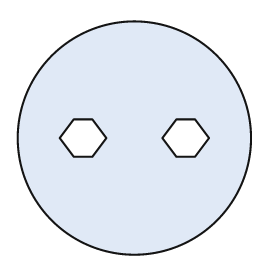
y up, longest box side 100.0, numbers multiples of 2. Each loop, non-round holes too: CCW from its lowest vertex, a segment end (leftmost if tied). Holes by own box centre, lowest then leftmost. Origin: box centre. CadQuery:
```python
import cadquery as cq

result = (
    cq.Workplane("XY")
    .moveTo(0.0, 0.0)
    .circle(50.0)
    .moveTo(-26.0, -8.0)
    .lineTo(-18.0, -8.0)
    .lineTo(-12.0, 0.0)
    .lineTo(-18.0, 8.0)
    .lineTo(-26.0, 8.0)
    .lineTo(-32.0, 0.0)
    .close()
    .moveTo(18.0, -8.0)
    .lineTo(26.0, -8.0)
    .lineTo(32.0, 0.0)
    .lineTo(26.0, 8.0)
    .lineTo(18.0, 8.0)
    .lineTo(12.0, 0.0)
    .close()
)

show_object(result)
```